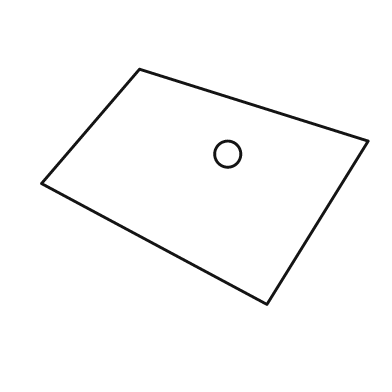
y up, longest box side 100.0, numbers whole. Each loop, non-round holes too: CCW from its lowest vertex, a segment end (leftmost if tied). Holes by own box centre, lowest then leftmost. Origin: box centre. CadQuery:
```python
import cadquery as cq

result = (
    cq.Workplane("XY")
    .moveTo(19.0, -36.0)
    .lineTo(50.0, 14.0)
    .lineTo(-20.0, 36.0)
    .lineTo(-50.0, 1.0)
    .close()
    .moveTo(7.0, 10.0)
    .circle(4.0)
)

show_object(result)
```